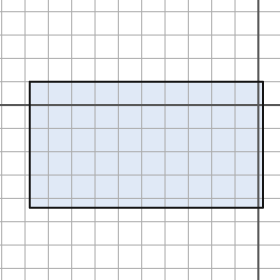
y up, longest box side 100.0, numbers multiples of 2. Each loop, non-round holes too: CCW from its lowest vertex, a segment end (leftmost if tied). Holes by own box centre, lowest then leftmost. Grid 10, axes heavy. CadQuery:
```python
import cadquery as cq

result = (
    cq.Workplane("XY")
    .moveTo(-98.0, -44.0)
    .lineTo(2.0, -44.0)
    .lineTo(2.0, 10.0)
    .lineTo(-98.0, 10.0)
    .close()
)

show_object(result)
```